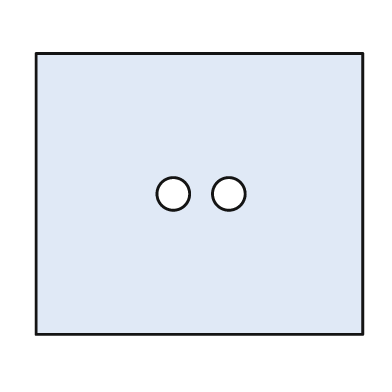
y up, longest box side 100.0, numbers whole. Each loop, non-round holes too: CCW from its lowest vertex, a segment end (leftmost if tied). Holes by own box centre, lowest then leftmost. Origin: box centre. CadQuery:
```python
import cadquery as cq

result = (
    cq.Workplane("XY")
    .moveTo(-50.0, -43.0)
    .lineTo(50.0, -43.0)
    .lineTo(50.0, 43.0)
    .lineTo(-50.0, 43.0)
    .close()
    .moveTo(-8.0, 0.0)
    .circle(5.0)
    .moveTo(9.0, 0.0)
    .circle(5.0)
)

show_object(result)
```